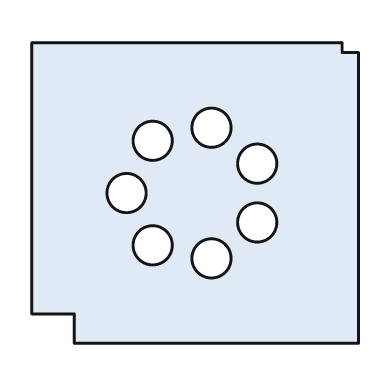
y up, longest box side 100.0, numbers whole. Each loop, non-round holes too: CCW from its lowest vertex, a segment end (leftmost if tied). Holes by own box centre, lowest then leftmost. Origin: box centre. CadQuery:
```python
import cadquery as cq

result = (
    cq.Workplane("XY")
    .moveTo(-37.0, -46.0)
    .lineTo(50.0, -46.0)
    .lineTo(50.0, 43.0)
    .lineTo(45.0, 43.0)
    .lineTo(45.0, 46.0)
    .lineTo(-50.0, 46.0)
    .lineTo(-50.0, -37.0)
    .lineTo(-37.0, -37.0)
    .close()
    .moveTo(5.0, -20.0)
    .circle(6.0)
    .moveTo(-13.0, -16.0)
    .circle(6.0)
    .moveTo(19.0, -9.0)
    .circle(6.0)
    .moveTo(-21.0, 0.0)
    .circle(6.0)
    .moveTo(19.0, 9.0)
    .circle(6.0)
    .moveTo(-13.0, 16.0)
    .circle(6.0)
    .moveTo(5.0, 20.0)
    .circle(6.0)
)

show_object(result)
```